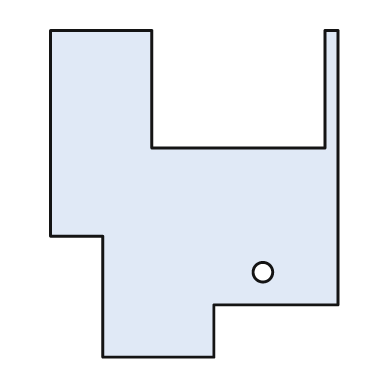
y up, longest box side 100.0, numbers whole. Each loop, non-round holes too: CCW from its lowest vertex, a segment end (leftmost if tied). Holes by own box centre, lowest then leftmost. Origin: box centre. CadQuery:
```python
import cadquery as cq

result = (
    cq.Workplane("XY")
    .moveTo(-28.0, -50.0)
    .lineTo(6.0, -50.0)
    .lineTo(6.0, -34.0)
    .lineTo(44.0, -34.0)
    .lineTo(44.0, 50.0)
    .lineTo(40.0, 50.0)
    .lineTo(40.0, 14.0)
    .lineTo(-13.0, 14.0)
    .lineTo(-13.0, 50.0)
    .lineTo(-44.0, 50.0)
    .lineTo(-44.0, -13.0)
    .lineTo(-28.0, -13.0)
    .close()
    .moveTo(21.0, -24.0)
    .circle(3.0)
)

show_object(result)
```